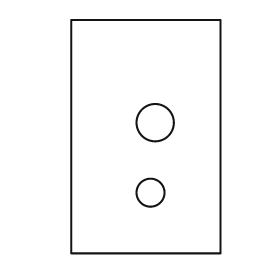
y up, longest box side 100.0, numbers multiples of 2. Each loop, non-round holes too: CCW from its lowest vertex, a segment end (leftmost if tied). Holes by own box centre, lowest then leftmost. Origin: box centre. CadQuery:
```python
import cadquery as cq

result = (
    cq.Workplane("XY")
    .moveTo(-32.0, -50.0)
    .lineTo(32.0, -50.0)
    .lineTo(32.0, 50.0)
    .lineTo(-32.0, 50.0)
    .close()
    .moveTo(2.0, -24.0)
    .circle(6.0)
    .moveTo(4.0, 6.0)
    .circle(8.0)
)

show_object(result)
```